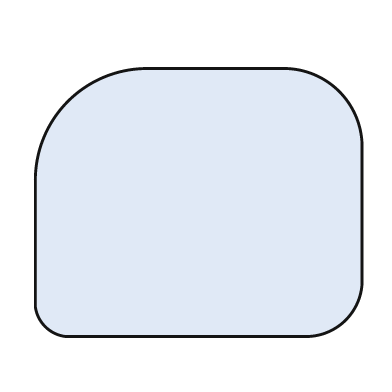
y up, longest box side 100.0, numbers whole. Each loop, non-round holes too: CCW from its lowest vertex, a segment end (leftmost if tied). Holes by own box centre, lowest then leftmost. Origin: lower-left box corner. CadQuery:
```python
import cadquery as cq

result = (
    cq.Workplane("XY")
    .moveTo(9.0, 0.0)
    .lineTo(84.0, 0.0)
    .threePointArc((95.0, 5.0), (100.0, 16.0))
    .lineTo(100.0, 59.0)
    .threePointArc((93.0, 75.0), (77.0, 82.0))
    .lineTo(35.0, 82.0)
    .threePointArc((10.0, 72.0), (0.0, 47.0))
    .lineTo(0.0, 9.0)
    .threePointArc((3.0, 3.0), (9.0, 0.0))
    .close()
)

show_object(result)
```